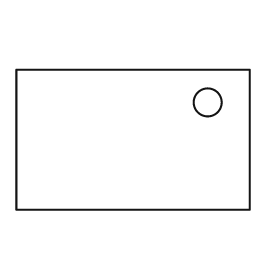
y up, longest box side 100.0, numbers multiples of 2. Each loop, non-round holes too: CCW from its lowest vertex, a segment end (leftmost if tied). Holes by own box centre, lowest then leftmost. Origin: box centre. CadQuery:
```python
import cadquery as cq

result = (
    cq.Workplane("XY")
    .moveTo(-50.0, -30.0)
    .lineTo(50.0, -30.0)
    .lineTo(50.0, 30.0)
    .lineTo(-50.0, 30.0)
    .close()
    .moveTo(32.0, 16.0)
    .circle(6.0)
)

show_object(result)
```